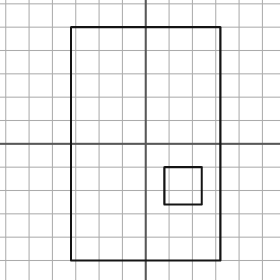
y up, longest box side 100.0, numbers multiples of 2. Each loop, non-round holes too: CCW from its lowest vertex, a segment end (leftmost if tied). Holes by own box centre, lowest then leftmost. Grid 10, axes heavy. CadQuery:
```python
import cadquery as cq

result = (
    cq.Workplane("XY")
    .moveTo(-32.0, -50.0)
    .lineTo(32.0, -50.0)
    .lineTo(32.0, 50.0)
    .lineTo(-32.0, 50.0)
    .close()
    .moveTo(8.0, -26.0)
    .lineTo(24.0, -26.0)
    .lineTo(24.0, -10.0)
    .lineTo(8.0, -10.0)
    .close()
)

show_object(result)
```